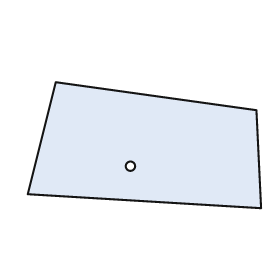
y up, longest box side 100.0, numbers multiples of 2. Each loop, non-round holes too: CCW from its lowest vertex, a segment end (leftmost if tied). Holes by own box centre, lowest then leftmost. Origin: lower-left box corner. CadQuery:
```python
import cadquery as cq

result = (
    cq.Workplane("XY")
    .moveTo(100.0, 0.0)
    .lineTo(98.0, 42.0)
    .lineTo(12.0, 54.0)
    .lineTo(0.0, 6.0)
    .close()
    .moveTo(44.0, 18.0)
    .circle(2.0)
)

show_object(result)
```